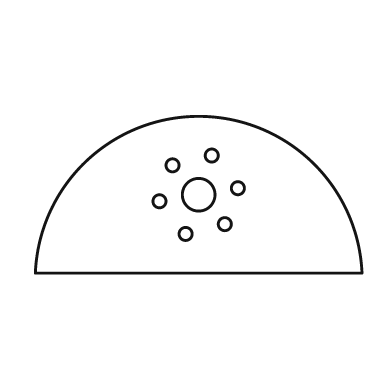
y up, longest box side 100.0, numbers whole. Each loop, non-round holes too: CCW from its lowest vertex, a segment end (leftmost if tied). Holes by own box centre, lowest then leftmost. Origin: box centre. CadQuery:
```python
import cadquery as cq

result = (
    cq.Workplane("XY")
    .moveTo(-50.0, -24.0)
    .lineTo(50.0, -24.0)
    .threePointArc((0.0, 24.0), (-50.0, -24.0))
    .close()
    .moveTo(-4.0, -12.0)
    .circle(2.0)
    .moveTo(8.0, -9.0)
    .circle(2.0)
    .moveTo(-12.0, -2.0)
    .circle(2.0)
    .moveTo(0.0, 0.0)
    .circle(5.0)
    .moveTo(12.0, 2.0)
    .circle(2.0)
    .moveTo(-8.0, 9.0)
    .circle(2.0)
    .moveTo(4.0, 12.0)
    .circle(2.0)
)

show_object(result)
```